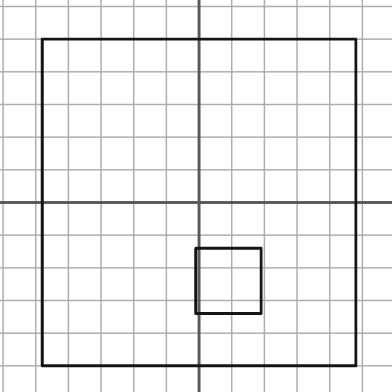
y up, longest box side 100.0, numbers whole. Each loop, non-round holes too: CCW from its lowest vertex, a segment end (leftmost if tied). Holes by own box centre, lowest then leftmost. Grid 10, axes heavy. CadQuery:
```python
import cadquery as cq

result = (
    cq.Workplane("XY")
    .moveTo(-48.0, -50.0)
    .lineTo(48.0, -50.0)
    .lineTo(48.0, 50.0)
    .lineTo(-48.0, 50.0)
    .close()
    .moveTo(-1.0, -34.0)
    .lineTo(19.0, -34.0)
    .lineTo(19.0, -14.0)
    .lineTo(-1.0, -14.0)
    .close()
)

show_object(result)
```